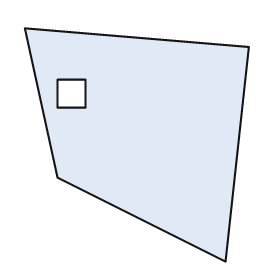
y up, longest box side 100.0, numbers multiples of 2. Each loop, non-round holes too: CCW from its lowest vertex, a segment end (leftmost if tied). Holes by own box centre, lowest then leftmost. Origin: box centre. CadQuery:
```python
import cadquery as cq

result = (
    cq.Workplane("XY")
    .moveTo(38.0, -50.0)
    .lineTo(48.0, 42.0)
    .lineTo(-48.0, 50.0)
    .lineTo(-34.0, -14.0)
    .close()
    .moveTo(-34.0, 16.0)
    .lineTo(-22.0, 16.0)
    .lineTo(-22.0, 28.0)
    .lineTo(-34.0, 28.0)
    .close()
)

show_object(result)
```